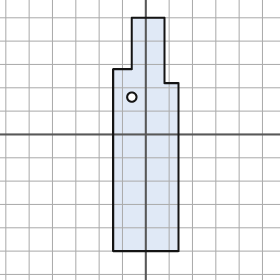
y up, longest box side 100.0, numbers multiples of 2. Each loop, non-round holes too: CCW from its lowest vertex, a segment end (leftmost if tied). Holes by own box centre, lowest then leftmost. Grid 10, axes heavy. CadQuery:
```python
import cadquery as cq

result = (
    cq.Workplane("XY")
    .moveTo(-14.0, -50.0)
    .lineTo(14.0, -50.0)
    .lineTo(14.0, 22.0)
    .lineTo(8.0, 22.0)
    .lineTo(8.0, 50.0)
    .lineTo(-6.0, 50.0)
    .lineTo(-6.0, 28.0)
    .lineTo(-14.0, 28.0)
    .close()
    .moveTo(-6.0, 16.0)
    .circle(2.0)
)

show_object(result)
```